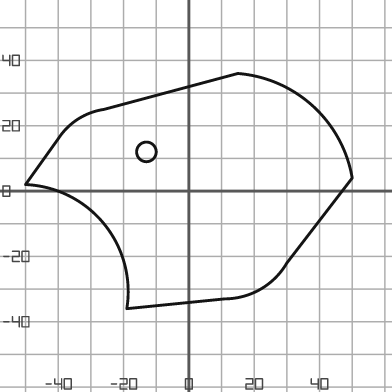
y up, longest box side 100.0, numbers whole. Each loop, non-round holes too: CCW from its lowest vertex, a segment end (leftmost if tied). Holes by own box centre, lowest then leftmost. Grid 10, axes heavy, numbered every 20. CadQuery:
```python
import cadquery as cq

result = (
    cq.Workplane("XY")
    .moveTo(-19.0, -36.0)
    .lineTo(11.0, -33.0)
    .threePointArc((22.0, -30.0), (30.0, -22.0))
    .lineTo(50.0, 4.0)
    .threePointArc((38.0, 26.0), (15.0, 36.0))
    .lineTo(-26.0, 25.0)
    .threePointArc((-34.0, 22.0), (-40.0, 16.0))
    .lineTo(-50.0, 2.0)
    .threePointArc((-26.0, -10.0), (-19.0, -36.0))
    .close()
    .moveTo(-13.0, 12.0)
    .circle(3.0)
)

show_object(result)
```